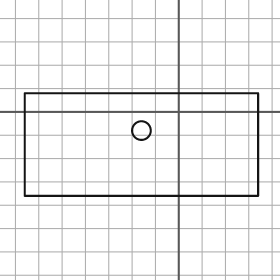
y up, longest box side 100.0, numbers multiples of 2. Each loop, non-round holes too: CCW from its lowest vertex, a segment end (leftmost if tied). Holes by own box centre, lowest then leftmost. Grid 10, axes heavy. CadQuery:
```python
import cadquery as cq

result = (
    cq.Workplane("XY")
    .moveTo(-66.0, -36.0)
    .lineTo(34.0, -36.0)
    .lineTo(34.0, 8.0)
    .lineTo(-66.0, 8.0)
    .close()
    .moveTo(-16.0, -8.0)
    .circle(4.0)
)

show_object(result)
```